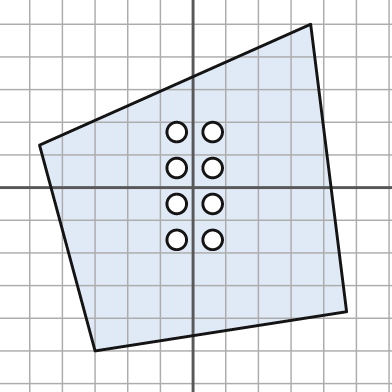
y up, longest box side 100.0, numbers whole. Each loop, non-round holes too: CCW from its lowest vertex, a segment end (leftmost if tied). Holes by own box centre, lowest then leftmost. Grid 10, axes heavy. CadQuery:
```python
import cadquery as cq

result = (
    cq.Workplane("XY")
    .moveTo(-30.0, -50.0)
    .lineTo(47.0, -38.0)
    .lineTo(36.0, 50.0)
    .lineTo(-47.0, 13.0)
    .close()
    .moveTo(-5.0, -16.0)
    .circle(3.0)
    .moveTo(6.0, -16.0)
    .circle(3.0)
    .moveTo(-5.0, -5.0)
    .circle(3.0)
    .moveTo(6.0, -5.0)
    .circle(3.0)
    .moveTo(-5.0, 6.0)
    .circle(3.0)
    .moveTo(6.0, 6.0)
    .circle(3.0)
    .moveTo(-5.0, 17.0)
    .circle(3.0)
    .moveTo(6.0, 17.0)
    .circle(3.0)
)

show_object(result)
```